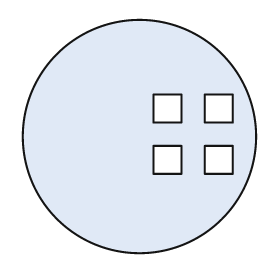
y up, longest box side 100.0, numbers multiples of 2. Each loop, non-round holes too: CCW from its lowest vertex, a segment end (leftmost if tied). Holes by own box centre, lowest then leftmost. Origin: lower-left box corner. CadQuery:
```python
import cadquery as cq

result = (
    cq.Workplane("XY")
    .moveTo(50.0, 50.0)
    .circle(50.0)
    .moveTo(56.0, 34.0)
    .lineTo(68.0, 34.0)
    .lineTo(68.0, 46.0)
    .lineTo(56.0, 46.0)
    .close()
    .moveTo(78.0, 34.0)
    .lineTo(90.0, 34.0)
    .lineTo(90.0, 46.0)
    .lineTo(78.0, 46.0)
    .close()
    .moveTo(56.0, 56.0)
    .lineTo(68.0, 56.0)
    .lineTo(68.0, 68.0)
    .lineTo(56.0, 68.0)
    .close()
    .moveTo(78.0, 56.0)
    .lineTo(90.0, 56.0)
    .lineTo(90.0, 68.0)
    .lineTo(78.0, 68.0)
    .close()
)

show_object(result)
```